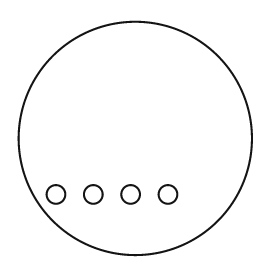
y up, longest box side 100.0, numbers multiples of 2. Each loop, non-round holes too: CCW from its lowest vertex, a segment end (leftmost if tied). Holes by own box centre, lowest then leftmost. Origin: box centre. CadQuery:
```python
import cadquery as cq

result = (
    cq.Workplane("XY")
    .moveTo(0.0, 0.0)
    .circle(50.0)
    .moveTo(-34.0, -24.0)
    .circle(4.0)
    .moveTo(-18.0, -24.0)
    .circle(4.0)
    .moveTo(-2.0, -24.0)
    .circle(4.0)
    .moveTo(14.0, -24.0)
    .circle(4.0)
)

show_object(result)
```